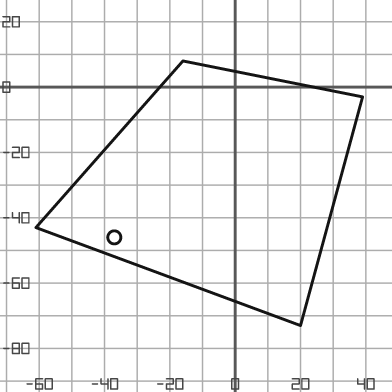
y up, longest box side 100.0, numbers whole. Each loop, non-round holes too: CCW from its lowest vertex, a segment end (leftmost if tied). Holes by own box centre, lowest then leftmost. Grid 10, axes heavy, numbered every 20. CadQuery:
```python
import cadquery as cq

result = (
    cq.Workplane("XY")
    .moveTo(20.0, -73.0)
    .lineTo(39.0, -3.0)
    .lineTo(-16.0, 8.0)
    .lineTo(-61.0, -43.0)
    .close()
    .moveTo(-37.0, -46.0)
    .circle(2.0)
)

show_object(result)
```